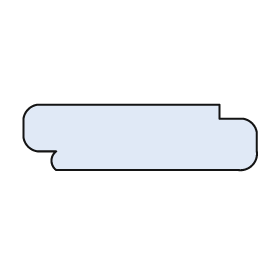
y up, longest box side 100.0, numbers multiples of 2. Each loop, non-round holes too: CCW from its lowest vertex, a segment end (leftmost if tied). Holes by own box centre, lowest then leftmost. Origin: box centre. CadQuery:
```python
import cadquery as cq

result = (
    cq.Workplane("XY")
    .moveTo(-36.0, -14.0)
    .lineTo(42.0, -14.0)
    .threePointArc((48.0, -12.0), (50.0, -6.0))
    .lineTo(50.0, 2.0)
    .threePointArc((48.0, 6.0), (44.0, 8.0))
    .lineTo(34.0, 8.0)
    .lineTo(34.0, 14.0)
    .lineTo(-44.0, 14.0)
    .threePointArc((-48.0, 12.0), (-50.0, 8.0))
    .lineTo(-50.0, 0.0)
    .threePointArc((-48.0, -4.0), (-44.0, -6.0))
    .lineTo(-36.0, -6.0)
    .threePointArc((-38.0, -10.0), (-36.0, -14.0))
    .close()
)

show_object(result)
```